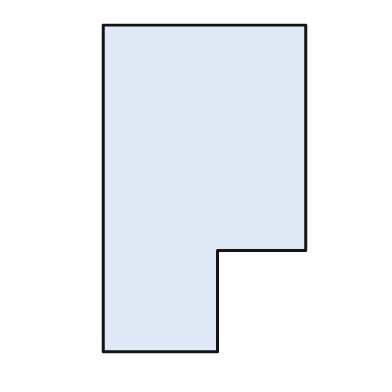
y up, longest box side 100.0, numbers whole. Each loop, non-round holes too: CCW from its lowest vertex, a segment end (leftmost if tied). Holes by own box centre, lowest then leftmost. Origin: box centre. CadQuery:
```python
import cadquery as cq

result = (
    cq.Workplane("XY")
    .moveTo(-31.0, -50.0)
    .lineTo(4.0, -50.0)
    .lineTo(4.0, -19.0)
    .lineTo(31.0, -19.0)
    .lineTo(31.0, 50.0)
    .lineTo(-31.0, 50.0)
    .close()
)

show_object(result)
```